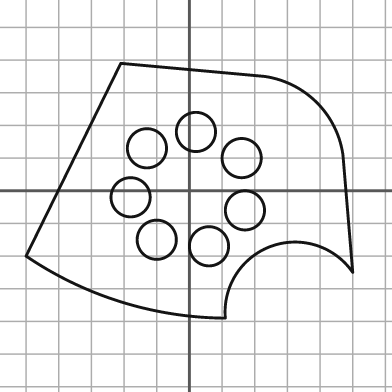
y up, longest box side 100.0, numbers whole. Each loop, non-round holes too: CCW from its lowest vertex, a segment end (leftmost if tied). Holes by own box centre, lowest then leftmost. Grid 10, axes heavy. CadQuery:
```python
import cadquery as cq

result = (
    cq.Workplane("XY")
    .moveTo(11.0, -39.0)
    .threePointArc((25.0, -17.0), (50.0, -25.0))
    .lineTo(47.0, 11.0)
    .threePointArc((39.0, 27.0), (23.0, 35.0))
    .lineTo(-21.0, 39.0)
    .lineTo(-50.0, -20.0)
    .threePointArc((-21.0, -34.0), (11.0, -39.0))
    .close()
    .moveTo(6.0, -17.0)
    .circle(6.0)
    .moveTo(-10.0, -15.0)
    .circle(6.0)
    .moveTo(17.0, -6.0)
    .circle(6.0)
    .moveTo(-18.0, -2.0)
    .circle(6.0)
    .moveTo(16.0, 10.0)
    .circle(6.0)
    .moveTo(-13.0, 13.0)
    .circle(6.0)
    .moveTo(2.0, 18.0)
    .circle(6.0)
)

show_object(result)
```